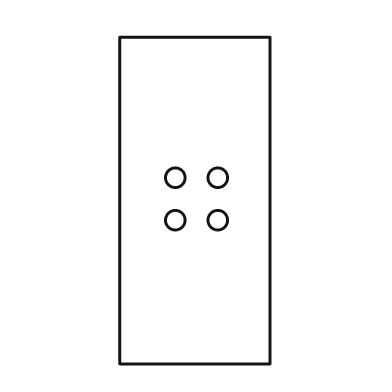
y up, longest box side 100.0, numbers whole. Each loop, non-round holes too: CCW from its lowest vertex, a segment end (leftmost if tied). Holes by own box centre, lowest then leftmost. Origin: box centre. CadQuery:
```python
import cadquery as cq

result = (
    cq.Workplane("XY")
    .moveTo(-23.0, -50.0)
    .lineTo(23.0, -50.0)
    .lineTo(23.0, 50.0)
    .lineTo(-23.0, 50.0)
    .close()
    .moveTo(-6.0, -6.0)
    .circle(3.0)
    .moveTo(7.0, -6.0)
    .circle(3.0)
    .moveTo(-6.0, 7.0)
    .circle(3.0)
    .moveTo(7.0, 7.0)
    .circle(3.0)
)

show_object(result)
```